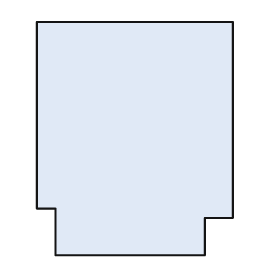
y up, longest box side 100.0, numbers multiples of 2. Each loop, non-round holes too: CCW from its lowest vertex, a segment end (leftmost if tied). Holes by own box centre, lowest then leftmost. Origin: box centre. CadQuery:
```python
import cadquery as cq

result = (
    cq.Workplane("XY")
    .moveTo(-34.0, -50.0)
    .lineTo(30.0, -50.0)
    .lineTo(30.0, -34.0)
    .lineTo(42.0, -34.0)
    .lineTo(42.0, 50.0)
    .lineTo(-42.0, 50.0)
    .lineTo(-42.0, -30.0)
    .lineTo(-34.0, -30.0)
    .close()
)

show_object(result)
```